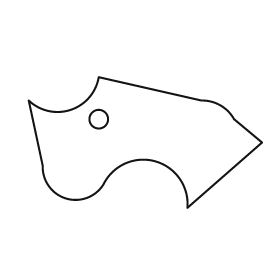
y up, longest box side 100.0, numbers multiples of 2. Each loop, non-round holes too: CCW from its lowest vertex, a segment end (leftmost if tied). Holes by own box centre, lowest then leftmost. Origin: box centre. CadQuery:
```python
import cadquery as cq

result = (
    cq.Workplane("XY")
    .moveTo(18.0, -28.0)
    .lineTo(50.0, 0.0)
    .lineTo(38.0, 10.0)
    .threePointArc((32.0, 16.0), (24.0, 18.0))
    .lineTo(-20.0, 28.0)
    .threePointArc((-32.0, 14.0), (-50.0, 18.0))
    .lineTo(-44.0, -10.0)
    .threePointArc((-34.0, -24.0), (-18.0, -18.0))
    .threePointArc((4.0, -8.0), (18.0, -28.0))
    .close()
    .moveTo(-20.0, 10.0)
    .circle(4.0)
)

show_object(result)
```